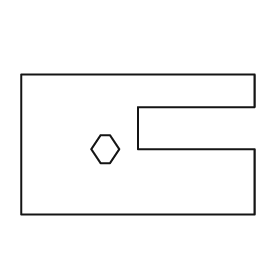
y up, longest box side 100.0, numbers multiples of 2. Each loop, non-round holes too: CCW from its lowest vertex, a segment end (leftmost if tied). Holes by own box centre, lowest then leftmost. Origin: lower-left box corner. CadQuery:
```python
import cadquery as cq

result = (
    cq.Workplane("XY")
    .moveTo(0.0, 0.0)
    .lineTo(100.0, 0.0)
    .lineTo(100.0, 28.0)
    .lineTo(50.0, 28.0)
    .lineTo(50.0, 46.0)
    .lineTo(100.0, 46.0)
    .lineTo(100.0, 60.0)
    .lineTo(0.0, 60.0)
    .close()
    .moveTo(34.0, 22.0)
    .lineTo(38.0, 22.0)
    .lineTo(42.0, 28.0)
    .lineTo(38.0, 34.0)
    .lineTo(34.0, 34.0)
    .lineTo(30.0, 28.0)
    .close()
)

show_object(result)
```